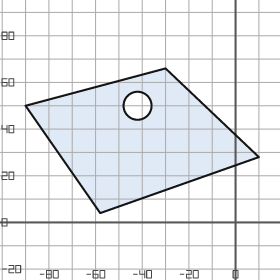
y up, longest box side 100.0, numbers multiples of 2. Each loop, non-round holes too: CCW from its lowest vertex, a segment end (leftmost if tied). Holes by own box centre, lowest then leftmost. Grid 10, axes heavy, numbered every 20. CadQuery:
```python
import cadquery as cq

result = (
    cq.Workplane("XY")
    .moveTo(-58.0, 4.0)
    .lineTo(10.0, 28.0)
    .lineTo(-30.0, 66.0)
    .lineTo(-90.0, 50.0)
    .close()
    .moveTo(-42.0, 50.0)
    .circle(6.0)
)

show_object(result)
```